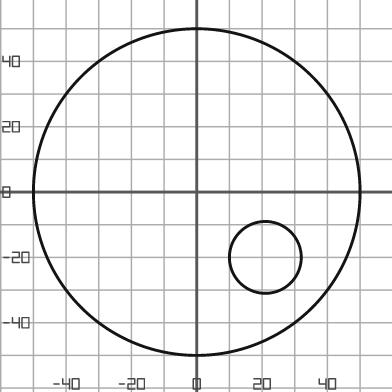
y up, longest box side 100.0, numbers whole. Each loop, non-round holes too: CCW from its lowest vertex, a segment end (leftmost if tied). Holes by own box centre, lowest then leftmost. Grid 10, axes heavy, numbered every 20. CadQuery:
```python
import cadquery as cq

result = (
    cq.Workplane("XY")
    .moveTo(0.0, 0.0)
    .circle(50.0)
    .moveTo(21.0, -20.0)
    .circle(11.0)
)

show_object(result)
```